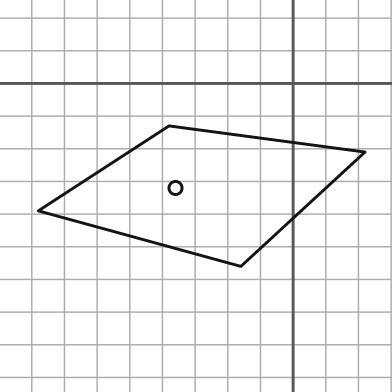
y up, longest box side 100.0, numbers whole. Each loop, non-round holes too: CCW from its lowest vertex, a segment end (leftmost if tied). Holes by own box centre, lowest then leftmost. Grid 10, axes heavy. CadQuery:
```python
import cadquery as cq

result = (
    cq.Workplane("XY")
    .moveTo(-16.0, -56.0)
    .lineTo(22.0, -21.0)
    .lineTo(-38.0, -13.0)
    .lineTo(-78.0, -39.0)
    .close()
    .moveTo(-36.0, -32.0)
    .circle(2.0)
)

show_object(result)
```